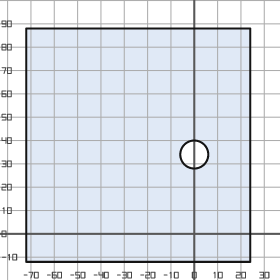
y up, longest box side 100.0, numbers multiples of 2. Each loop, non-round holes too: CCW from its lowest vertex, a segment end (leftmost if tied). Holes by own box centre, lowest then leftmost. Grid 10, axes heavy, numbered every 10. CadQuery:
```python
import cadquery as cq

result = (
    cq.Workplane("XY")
    .moveTo(-72.0, -12.0)
    .lineTo(24.0, -12.0)
    .lineTo(24.0, 88.0)
    .lineTo(-72.0, 88.0)
    .close()
    .moveTo(0.0, 34.0)
    .circle(6.0)
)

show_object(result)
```